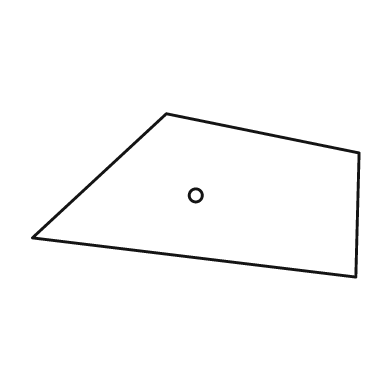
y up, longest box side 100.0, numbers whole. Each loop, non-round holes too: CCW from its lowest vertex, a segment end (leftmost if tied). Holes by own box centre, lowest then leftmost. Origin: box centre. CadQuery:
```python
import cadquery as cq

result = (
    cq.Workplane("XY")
    .moveTo(49.0, -25.0)
    .lineTo(50.0, 13.0)
    .lineTo(-9.0, 25.0)
    .lineTo(-50.0, -13.0)
    .close()
    .moveTo(0.0, 0.0)
    .circle(2.0)
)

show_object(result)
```